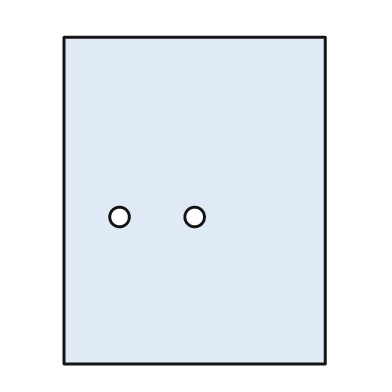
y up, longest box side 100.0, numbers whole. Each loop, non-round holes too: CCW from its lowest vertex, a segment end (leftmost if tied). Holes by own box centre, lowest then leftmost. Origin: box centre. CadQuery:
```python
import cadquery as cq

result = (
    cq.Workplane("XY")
    .moveTo(-40.0, -50.0)
    .lineTo(40.0, -50.0)
    .lineTo(40.0, 50.0)
    .lineTo(-40.0, 50.0)
    .close()
    .moveTo(-23.0, -5.0)
    .circle(3.0)
    .moveTo(0.0, -5.0)
    .circle(3.0)
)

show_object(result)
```